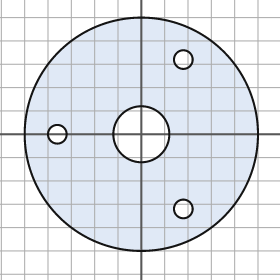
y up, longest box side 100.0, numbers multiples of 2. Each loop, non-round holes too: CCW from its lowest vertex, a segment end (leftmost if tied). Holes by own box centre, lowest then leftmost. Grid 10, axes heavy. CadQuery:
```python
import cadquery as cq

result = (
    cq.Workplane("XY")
    .moveTo(0.0, 0.0)
    .circle(50.0)
    .moveTo(18.0, -32.0)
    .circle(4.0)
    .moveTo(-36.0, 0.0)
    .circle(4.0)
    .moveTo(0.0, 0.0)
    .circle(12.0)
    .moveTo(18.0, 32.0)
    .circle(4.0)
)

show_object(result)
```